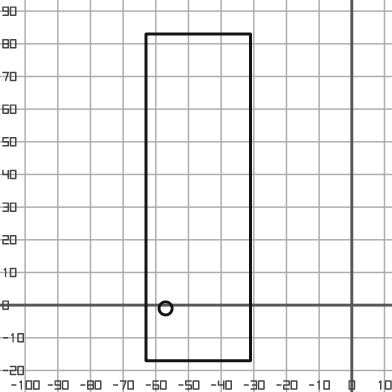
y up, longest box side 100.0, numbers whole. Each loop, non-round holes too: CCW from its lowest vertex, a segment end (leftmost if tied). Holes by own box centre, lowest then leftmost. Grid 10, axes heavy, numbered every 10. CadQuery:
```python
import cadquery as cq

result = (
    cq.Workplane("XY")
    .moveTo(-63.0, -17.0)
    .lineTo(-31.0, -17.0)
    .lineTo(-31.0, 83.0)
    .lineTo(-63.0, 83.0)
    .close()
    .moveTo(-57.0, -1.0)
    .circle(2.0)
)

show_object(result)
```